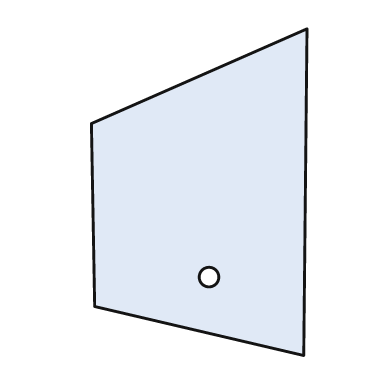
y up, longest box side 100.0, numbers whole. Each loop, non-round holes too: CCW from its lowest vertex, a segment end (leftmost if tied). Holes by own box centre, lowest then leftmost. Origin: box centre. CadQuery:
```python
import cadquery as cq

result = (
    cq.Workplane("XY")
    .moveTo(32.0, -50.0)
    .lineTo(33.0, 50.0)
    .lineTo(-33.0, 21.0)
    .lineTo(-32.0, -35.0)
    .close()
    .moveTo(3.0, -26.0)
    .circle(3.0)
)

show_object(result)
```